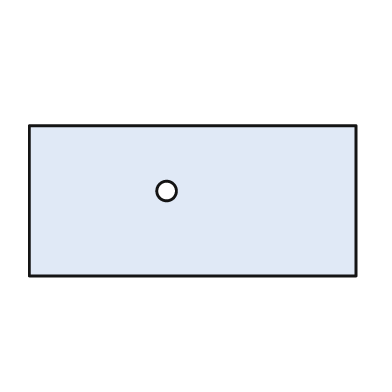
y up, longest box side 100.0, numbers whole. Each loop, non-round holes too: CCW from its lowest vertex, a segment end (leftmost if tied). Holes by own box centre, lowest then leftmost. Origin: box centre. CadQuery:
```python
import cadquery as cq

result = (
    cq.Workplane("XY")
    .moveTo(-50.0, -23.0)
    .lineTo(50.0, -23.0)
    .lineTo(50.0, 23.0)
    .lineTo(-50.0, 23.0)
    .close()
    .moveTo(-8.0, 3.0)
    .circle(3.0)
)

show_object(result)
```